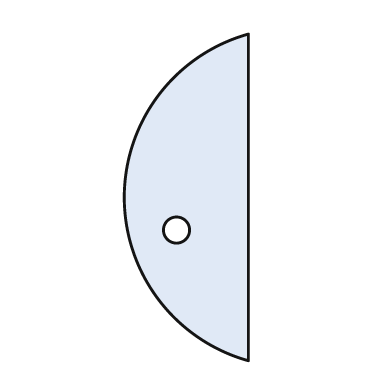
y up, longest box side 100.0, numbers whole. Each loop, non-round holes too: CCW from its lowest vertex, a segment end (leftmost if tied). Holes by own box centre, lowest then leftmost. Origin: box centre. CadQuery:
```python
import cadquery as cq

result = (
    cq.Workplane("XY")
    .moveTo(19.0, -50.0)
    .lineTo(19.0, 50.0)
    .threePointArc((-19.0, 0.0), (19.0, -50.0))
    .close()
    .moveTo(-3.0, -10.0)
    .circle(4.0)
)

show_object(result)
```